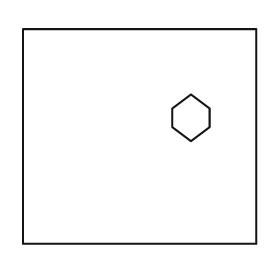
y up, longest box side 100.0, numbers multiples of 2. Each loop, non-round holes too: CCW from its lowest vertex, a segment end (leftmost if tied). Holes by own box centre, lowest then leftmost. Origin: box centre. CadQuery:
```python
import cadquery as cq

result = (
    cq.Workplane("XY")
    .moveTo(-50.0, -46.0)
    .lineTo(50.0, -46.0)
    .lineTo(50.0, 46.0)
    .lineTo(-50.0, 46.0)
    .close()
    .moveTo(22.0, -2.0)
    .lineTo(30.0, 4.0)
    .lineTo(30.0, 12.0)
    .lineTo(22.0, 18.0)
    .lineTo(14.0, 12.0)
    .lineTo(14.0, 4.0)
    .close()
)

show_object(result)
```